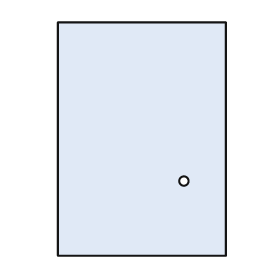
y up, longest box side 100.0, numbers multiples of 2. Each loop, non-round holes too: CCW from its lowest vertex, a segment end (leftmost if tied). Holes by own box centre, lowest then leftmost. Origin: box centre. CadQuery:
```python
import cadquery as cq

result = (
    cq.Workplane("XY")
    .moveTo(-36.0, -50.0)
    .lineTo(36.0, -50.0)
    .lineTo(36.0, 50.0)
    .lineTo(-36.0, 50.0)
    .close()
    .moveTo(18.0, -18.0)
    .circle(2.0)
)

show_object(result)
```